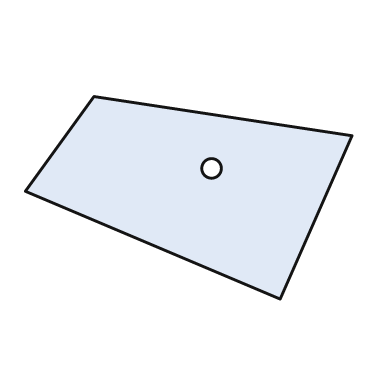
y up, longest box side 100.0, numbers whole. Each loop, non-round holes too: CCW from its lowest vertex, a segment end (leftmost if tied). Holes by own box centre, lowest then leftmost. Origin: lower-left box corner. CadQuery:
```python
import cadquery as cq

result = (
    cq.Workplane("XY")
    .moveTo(78.0, 0.0)
    .lineTo(100.0, 50.0)
    .lineTo(21.0, 62.0)
    .lineTo(0.0, 33.0)
    .close()
    .moveTo(57.0, 40.0)
    .circle(3.0)
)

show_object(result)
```